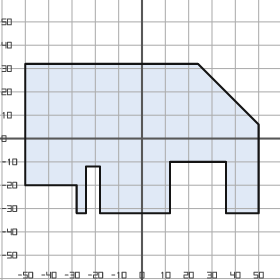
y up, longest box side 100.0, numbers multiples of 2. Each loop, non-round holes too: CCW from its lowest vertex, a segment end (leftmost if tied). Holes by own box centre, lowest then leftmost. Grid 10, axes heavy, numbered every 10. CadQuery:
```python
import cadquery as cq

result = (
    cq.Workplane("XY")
    .moveTo(-28.0, -32.0)
    .lineTo(-24.0, -32.0)
    .lineTo(-24.0, -12.0)
    .lineTo(-18.0, -12.0)
    .lineTo(-18.0, -32.0)
    .lineTo(12.0, -32.0)
    .lineTo(12.0, -10.0)
    .lineTo(36.0, -10.0)
    .lineTo(36.0, -32.0)
    .lineTo(50.0, -32.0)
    .lineTo(50.0, 6.0)
    .lineTo(24.0, 32.0)
    .lineTo(-50.0, 32.0)
    .lineTo(-50.0, -20.0)
    .lineTo(-28.0, -20.0)
    .close()
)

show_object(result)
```